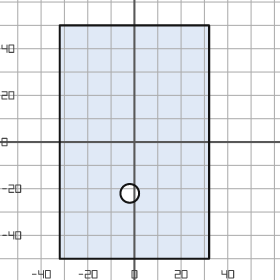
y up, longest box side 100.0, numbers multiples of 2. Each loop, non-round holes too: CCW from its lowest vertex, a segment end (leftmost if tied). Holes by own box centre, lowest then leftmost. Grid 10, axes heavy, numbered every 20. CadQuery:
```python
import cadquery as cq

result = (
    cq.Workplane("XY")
    .moveTo(-32.0, -50.0)
    .lineTo(32.0, -50.0)
    .lineTo(32.0, 50.0)
    .lineTo(-32.0, 50.0)
    .close()
    .moveTo(-2.0, -22.0)
    .circle(4.0)
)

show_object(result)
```